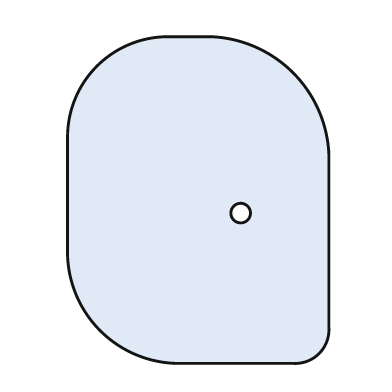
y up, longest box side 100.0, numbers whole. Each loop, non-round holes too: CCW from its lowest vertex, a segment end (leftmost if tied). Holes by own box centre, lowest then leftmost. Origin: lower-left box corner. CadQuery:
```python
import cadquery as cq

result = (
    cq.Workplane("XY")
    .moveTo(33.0, 0.0)
    .lineTo(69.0, 0.0)
    .threePointArc((77.0, 3.0), (80.0, 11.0))
    .lineTo(80.0, 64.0)
    .threePointArc((69.0, 89.0), (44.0, 100.0))
    .lineTo(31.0, 100.0)
    .threePointArc((9.0, 91.0), (0.0, 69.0))
    .lineTo(0.0, 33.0)
    .threePointArc((10.0, 10.0), (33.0, 0.0))
    .close()
    .moveTo(53.0, 46.0)
    .circle(3.0)
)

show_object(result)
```